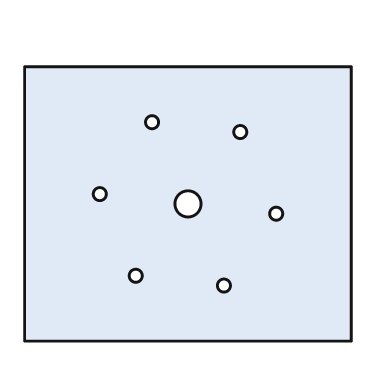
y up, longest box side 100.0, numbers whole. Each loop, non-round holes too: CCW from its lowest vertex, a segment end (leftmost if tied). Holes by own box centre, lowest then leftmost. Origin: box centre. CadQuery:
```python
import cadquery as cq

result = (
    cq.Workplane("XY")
    .moveTo(-50.0, -42.0)
    .lineTo(50.0, -42.0)
    .lineTo(50.0, 42.0)
    .lineTo(-50.0, 42.0)
    .close()
    .moveTo(11.0, -25.0)
    .circle(2.0)
    .moveTo(-16.0, -22.0)
    .circle(2.0)
    .moveTo(27.0, -3.0)
    .circle(2.0)
    .moveTo(0.0, 0.0)
    .circle(4.0)
    .moveTo(-27.0, 3.0)
    .circle(2.0)
    .moveTo(16.0, 22.0)
    .circle(2.0)
    .moveTo(-11.0, 25.0)
    .circle(2.0)
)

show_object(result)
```